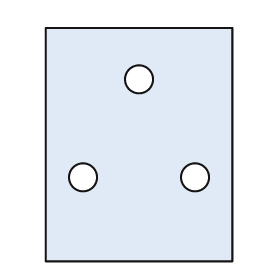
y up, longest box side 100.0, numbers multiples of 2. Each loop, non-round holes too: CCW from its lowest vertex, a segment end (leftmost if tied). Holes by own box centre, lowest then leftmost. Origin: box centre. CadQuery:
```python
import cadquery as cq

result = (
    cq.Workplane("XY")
    .moveTo(-40.0, -50.0)
    .lineTo(40.0, -50.0)
    .lineTo(40.0, 50.0)
    .lineTo(-40.0, 50.0)
    .close()
    .moveTo(-24.0, -14.0)
    .circle(6.0)
    .moveTo(24.0, -14.0)
    .circle(6.0)
    .moveTo(0.0, 28.0)
    .circle(6.0)
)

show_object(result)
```